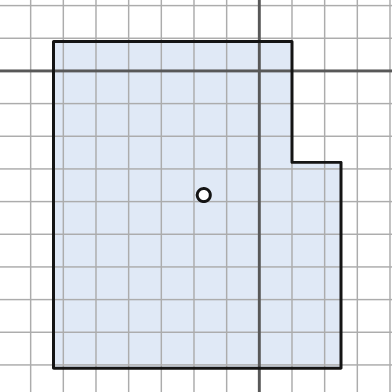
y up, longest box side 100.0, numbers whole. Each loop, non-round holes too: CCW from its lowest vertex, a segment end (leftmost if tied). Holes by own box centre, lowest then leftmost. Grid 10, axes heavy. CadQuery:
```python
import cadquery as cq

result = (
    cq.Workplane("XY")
    .moveTo(-63.0, -91.0)
    .lineTo(25.0, -91.0)
    .lineTo(25.0, -28.0)
    .lineTo(10.0, -28.0)
    .lineTo(10.0, 9.0)
    .lineTo(-63.0, 9.0)
    .close()
    .moveTo(-17.0, -38.0)
    .circle(2.0)
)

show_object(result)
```